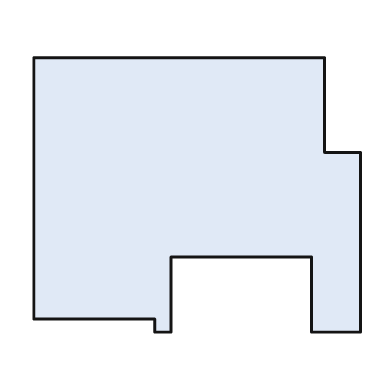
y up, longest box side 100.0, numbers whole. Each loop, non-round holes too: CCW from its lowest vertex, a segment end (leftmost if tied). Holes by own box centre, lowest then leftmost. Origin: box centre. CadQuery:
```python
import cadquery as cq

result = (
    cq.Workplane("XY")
    .moveTo(-13.0, -42.0)
    .lineTo(-8.0, -42.0)
    .lineTo(-8.0, -19.0)
    .lineTo(35.0, -19.0)
    .lineTo(35.0, -42.0)
    .lineTo(50.0, -42.0)
    .lineTo(50.0, 13.0)
    .lineTo(39.0, 13.0)
    .lineTo(39.0, 42.0)
    .lineTo(-50.0, 42.0)
    .lineTo(-50.0, -38.0)
    .lineTo(-13.0, -38.0)
    .close()
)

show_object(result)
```